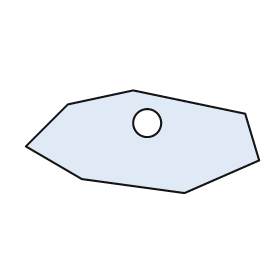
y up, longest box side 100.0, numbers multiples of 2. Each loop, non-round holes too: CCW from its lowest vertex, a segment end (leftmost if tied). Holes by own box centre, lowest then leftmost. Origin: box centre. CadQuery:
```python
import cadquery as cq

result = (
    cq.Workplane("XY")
    .moveTo(18.0, -22.0)
    .lineTo(50.0, -8.0)
    .lineTo(44.0, 12.0)
    .lineTo(-4.0, 22.0)
    .lineTo(-32.0, 16.0)
    .lineTo(-50.0, -2.0)
    .lineTo(-26.0, -16.0)
    .close()
    .moveTo(2.0, 8.0)
    .circle(6.0)
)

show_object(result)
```